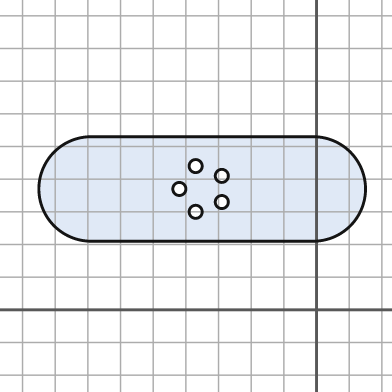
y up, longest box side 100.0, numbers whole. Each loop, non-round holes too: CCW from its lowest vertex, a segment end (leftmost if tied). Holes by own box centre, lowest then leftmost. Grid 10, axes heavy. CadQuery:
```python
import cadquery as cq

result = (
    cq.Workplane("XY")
    .moveTo(-69.0, 21.0)
    .lineTo(-1.0, 21.0)
    .threePointArc((15.0, 37.0), (-1.0, 53.0))
    .lineTo(-69.0, 53.0)
    .threePointArc((-85.0, 37.0), (-69.0, 21.0))
    .close()
    .moveTo(-37.0, 30.0)
    .circle(2.0)
    .moveTo(-29.0, 33.0)
    .circle(2.0)
    .moveTo(-42.0, 37.0)
    .circle(2.0)
    .moveTo(-29.0, 41.0)
    .circle(2.0)
    .moveTo(-37.0, 44.0)
    .circle(2.0)
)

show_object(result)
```